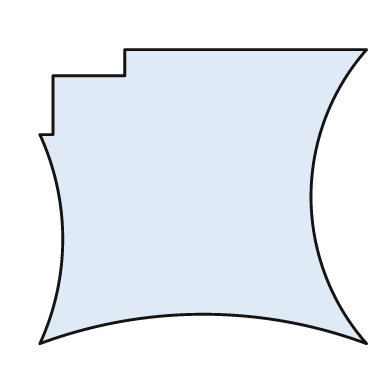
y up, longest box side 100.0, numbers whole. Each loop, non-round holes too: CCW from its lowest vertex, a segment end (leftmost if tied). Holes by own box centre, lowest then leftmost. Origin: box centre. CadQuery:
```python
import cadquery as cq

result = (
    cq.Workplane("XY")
    .moveTo(-50.0, -45.0)
    .threePointArc((0.0, -36.0), (50.0, -45.0))
    .threePointArc((33.0, 0.0), (50.0, 45.0))
    .lineTo(-24.0, 45.0)
    .lineTo(-24.0, 37.0)
    .lineTo(-46.0, 37.0)
    .lineTo(-46.0, 19.0)
    .lineTo(-50.0, 19.0)
    .threePointArc((-43.0, -13.0), (-50.0, -45.0))
    .close()
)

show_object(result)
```